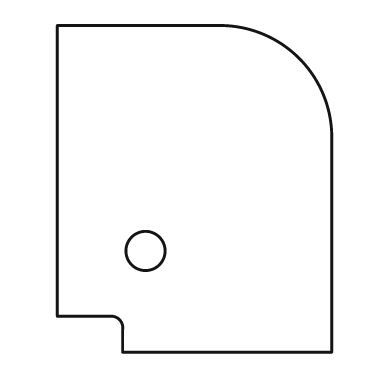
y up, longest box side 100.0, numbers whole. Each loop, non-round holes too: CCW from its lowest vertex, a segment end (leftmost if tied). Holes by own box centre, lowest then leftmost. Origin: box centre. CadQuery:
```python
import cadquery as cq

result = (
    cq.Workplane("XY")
    .moveTo(-22.0, -50.0)
    .lineTo(42.0, -50.0)
    .lineTo(42.0, 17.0)
    .threePointArc((32.0, 40.0), (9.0, 50.0))
    .lineTo(-42.0, 50.0)
    .lineTo(-42.0, -39.0)
    .lineTo(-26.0, -39.0)
    .threePointArc((-23.0, -40.0), (-22.0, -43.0))
    .close()
    .moveTo(-15.0, -19.0)
    .circle(6.0)
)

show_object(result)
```